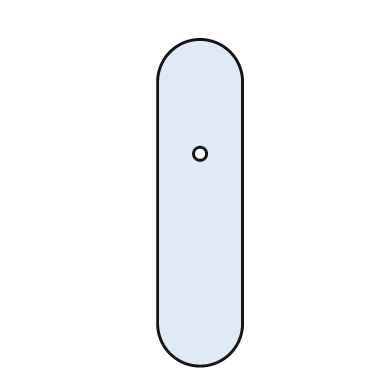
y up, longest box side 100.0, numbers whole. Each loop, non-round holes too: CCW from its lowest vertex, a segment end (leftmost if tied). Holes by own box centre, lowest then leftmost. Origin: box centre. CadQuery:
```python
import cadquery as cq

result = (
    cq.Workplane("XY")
    .moveTo(-13.0, -37.0)
    .threePointArc((0.0, -50.0), (13.0, -37.0))
    .lineTo(13.0, 37.0)
    .threePointArc((0.0, 50.0), (-13.0, 37.0))
    .close()
    .moveTo(0.0, 15.0)
    .circle(2.0)
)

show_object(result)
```